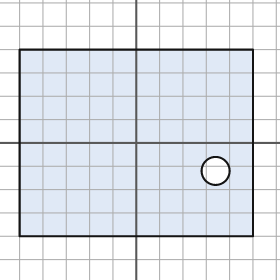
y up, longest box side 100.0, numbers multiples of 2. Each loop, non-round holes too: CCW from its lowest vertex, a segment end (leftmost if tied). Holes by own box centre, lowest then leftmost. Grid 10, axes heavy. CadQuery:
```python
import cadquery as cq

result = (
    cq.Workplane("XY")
    .moveTo(-50.0, -40.0)
    .lineTo(50.0, -40.0)
    .lineTo(50.0, 40.0)
    .lineTo(-50.0, 40.0)
    .close()
    .moveTo(34.0, -12.0)
    .circle(6.0)
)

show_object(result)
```